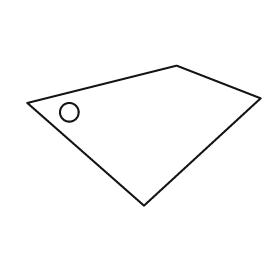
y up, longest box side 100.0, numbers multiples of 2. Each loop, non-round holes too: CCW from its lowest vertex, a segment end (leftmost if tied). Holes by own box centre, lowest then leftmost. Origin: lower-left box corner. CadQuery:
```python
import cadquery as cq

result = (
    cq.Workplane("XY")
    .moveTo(50.0, 0.0)
    .lineTo(100.0, 46.0)
    .lineTo(64.0, 60.0)
    .lineTo(0.0, 44.0)
    .close()
    .moveTo(18.0, 40.0)
    .circle(4.0)
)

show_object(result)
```